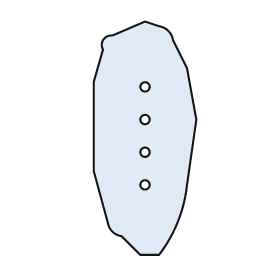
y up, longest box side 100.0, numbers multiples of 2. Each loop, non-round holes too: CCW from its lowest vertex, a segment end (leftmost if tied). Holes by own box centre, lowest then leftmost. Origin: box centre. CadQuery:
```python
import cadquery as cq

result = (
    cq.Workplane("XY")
    .moveTo(-2.0, -50.0)
    .lineTo(6.0, -50.0)
    .threePointArc((14.0, -36.0), (18.0, -20.0))
    .lineTo(22.0, 8.0)
    .lineTo(18.0, 30.0)
    .lineTo(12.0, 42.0)
    .threePointArc((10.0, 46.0), (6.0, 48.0))
    .lineTo(0.0, 50.0)
    .lineTo(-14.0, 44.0)
    .threePointArc((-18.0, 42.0), (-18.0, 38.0))
    .lineTo(-22.0, 24.0)
    .lineTo(-22.0, -14.0)
    .lineTo(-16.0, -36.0)
    .threePointArc((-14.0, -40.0), (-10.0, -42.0))
    .close()
    .moveTo(0.0, -20.0)
    .circle(2.0)
    .moveTo(0.0, -6.0)
    .circle(2.0)
    .moveTo(0.0, 8.0)
    .circle(2.0)
    .moveTo(0.0, 22.0)
    .circle(2.0)
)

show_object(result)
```